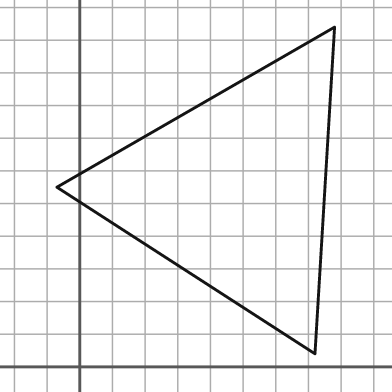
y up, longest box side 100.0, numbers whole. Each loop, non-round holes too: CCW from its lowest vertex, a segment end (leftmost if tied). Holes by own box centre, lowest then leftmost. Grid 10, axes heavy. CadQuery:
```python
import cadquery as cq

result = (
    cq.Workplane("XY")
    .moveTo(72.0, 4.0)
    .lineTo(78.0, 104.0)
    .lineTo(-7.0, 55.0)
    .close()
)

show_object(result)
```